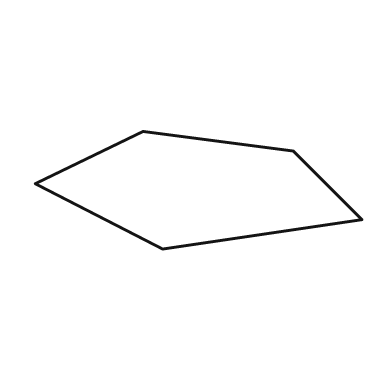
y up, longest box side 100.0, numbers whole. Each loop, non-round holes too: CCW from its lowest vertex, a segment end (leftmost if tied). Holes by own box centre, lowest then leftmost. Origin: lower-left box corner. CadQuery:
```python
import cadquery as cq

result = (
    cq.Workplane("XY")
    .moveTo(39.0, 0.0)
    .lineTo(100.0, 9.0)
    .lineTo(79.0, 30.0)
    .lineTo(33.0, 36.0)
    .lineTo(0.0, 20.0)
    .close()
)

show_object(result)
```